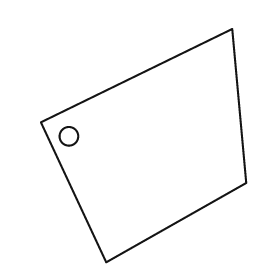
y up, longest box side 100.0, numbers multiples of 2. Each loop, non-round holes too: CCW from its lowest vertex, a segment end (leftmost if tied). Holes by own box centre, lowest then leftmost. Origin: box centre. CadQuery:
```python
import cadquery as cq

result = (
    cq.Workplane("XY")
    .moveTo(-16.0, -50.0)
    .lineTo(44.0, -16.0)
    .lineTo(38.0, 50.0)
    .lineTo(-44.0, 10.0)
    .close()
    .moveTo(-32.0, 4.0)
    .circle(4.0)
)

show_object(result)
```